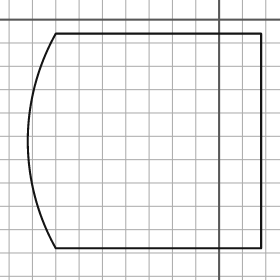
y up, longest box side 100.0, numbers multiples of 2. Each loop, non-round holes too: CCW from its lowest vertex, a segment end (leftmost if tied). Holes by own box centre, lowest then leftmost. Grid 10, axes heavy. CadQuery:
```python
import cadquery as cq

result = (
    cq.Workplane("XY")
    .moveTo(-70.0, -98.0)
    .lineTo(18.0, -98.0)
    .lineTo(18.0, -6.0)
    .lineTo(-70.0, -6.0)
    .threePointArc((-82.0, -52.0), (-70.0, -98.0))
    .close()
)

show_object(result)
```